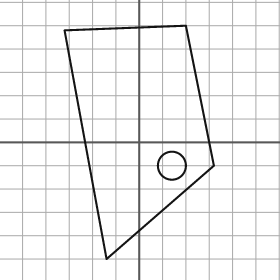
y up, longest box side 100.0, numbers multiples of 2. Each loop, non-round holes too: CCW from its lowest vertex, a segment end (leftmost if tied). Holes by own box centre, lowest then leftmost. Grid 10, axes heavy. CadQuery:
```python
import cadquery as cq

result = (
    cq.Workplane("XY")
    .moveTo(-14.0, -50.0)
    .lineTo(32.0, -10.0)
    .lineTo(20.0, 50.0)
    .lineTo(-32.0, 48.0)
    .close()
    .moveTo(14.0, -10.0)
    .circle(6.0)
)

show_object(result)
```